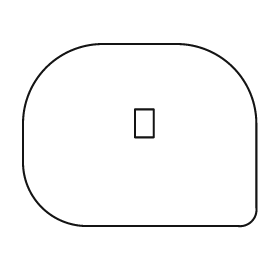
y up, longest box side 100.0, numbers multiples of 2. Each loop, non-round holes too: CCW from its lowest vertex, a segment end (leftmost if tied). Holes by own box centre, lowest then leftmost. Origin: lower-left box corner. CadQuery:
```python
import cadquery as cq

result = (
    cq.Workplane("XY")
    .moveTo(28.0, 0.0)
    .lineTo(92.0, 0.0)
    .threePointArc((98.0, 2.0), (100.0, 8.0))
    .lineTo(100.0, 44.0)
    .threePointArc((90.0, 68.0), (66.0, 78.0))
    .lineTo(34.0, 78.0)
    .threePointArc((10.0, 68.0), (0.0, 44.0))
    .lineTo(0.0, 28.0)
    .threePointArc((8.0, 8.0), (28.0, 0.0))
    .close()
    .moveTo(48.0, 38.0)
    .lineTo(56.0, 38.0)
    .lineTo(56.0, 50.0)
    .lineTo(48.0, 50.0)
    .close()
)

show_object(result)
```